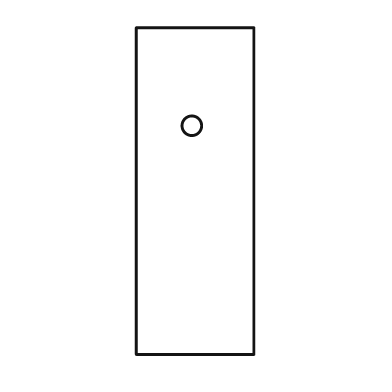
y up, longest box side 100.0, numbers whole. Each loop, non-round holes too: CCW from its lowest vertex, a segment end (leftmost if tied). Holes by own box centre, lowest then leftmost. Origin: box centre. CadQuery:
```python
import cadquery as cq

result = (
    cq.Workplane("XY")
    .moveTo(-18.0, -50.0)
    .lineTo(18.0, -50.0)
    .lineTo(18.0, 50.0)
    .lineTo(-18.0, 50.0)
    .close()
    .moveTo(-1.0, 20.0)
    .circle(3.0)
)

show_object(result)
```